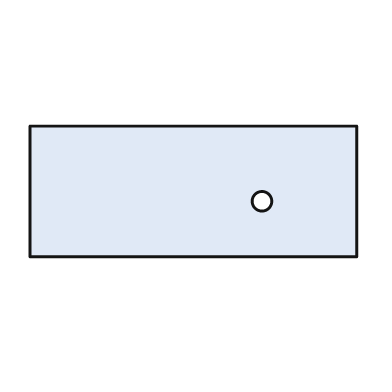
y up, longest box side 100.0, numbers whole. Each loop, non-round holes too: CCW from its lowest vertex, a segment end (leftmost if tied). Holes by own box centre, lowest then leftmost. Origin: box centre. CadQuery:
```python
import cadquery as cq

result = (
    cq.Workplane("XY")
    .moveTo(-50.0, -20.0)
    .lineTo(50.0, -20.0)
    .lineTo(50.0, 20.0)
    .lineTo(-50.0, 20.0)
    .close()
    .moveTo(21.0, -3.0)
    .circle(3.0)
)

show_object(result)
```